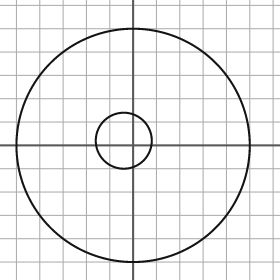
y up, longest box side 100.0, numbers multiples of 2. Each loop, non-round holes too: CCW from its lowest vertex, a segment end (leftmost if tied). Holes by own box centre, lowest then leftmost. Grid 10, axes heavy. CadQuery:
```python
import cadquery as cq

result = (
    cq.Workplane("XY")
    .moveTo(0.0, 0.0)
    .circle(50.0)
    .moveTo(-4.0, 2.0)
    .circle(12.0)
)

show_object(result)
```